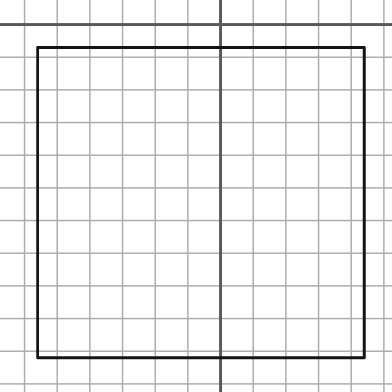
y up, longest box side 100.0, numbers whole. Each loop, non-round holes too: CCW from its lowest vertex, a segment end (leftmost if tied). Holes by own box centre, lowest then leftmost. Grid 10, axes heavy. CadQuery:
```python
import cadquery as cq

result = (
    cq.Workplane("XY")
    .moveTo(-56.0, -102.0)
    .lineTo(44.0, -102.0)
    .lineTo(44.0, -7.0)
    .lineTo(-56.0, -7.0)
    .close()
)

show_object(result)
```